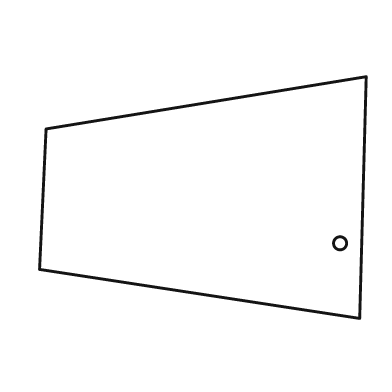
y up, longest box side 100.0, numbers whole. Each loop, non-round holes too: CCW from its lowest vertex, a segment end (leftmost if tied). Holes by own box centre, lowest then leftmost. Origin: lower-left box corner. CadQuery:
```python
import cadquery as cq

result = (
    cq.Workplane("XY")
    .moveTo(98.0, 0.0)
    .lineTo(100.0, 74.0)
    .lineTo(2.0, 58.0)
    .lineTo(0.0, 15.0)
    .close()
    .moveTo(92.0, 23.0)
    .circle(2.0)
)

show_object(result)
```